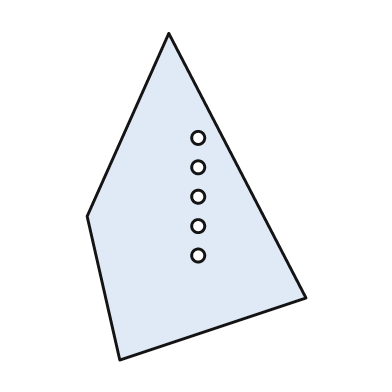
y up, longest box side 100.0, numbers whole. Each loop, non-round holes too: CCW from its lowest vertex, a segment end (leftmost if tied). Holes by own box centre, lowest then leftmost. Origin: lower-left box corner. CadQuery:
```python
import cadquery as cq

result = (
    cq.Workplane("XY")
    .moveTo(10.0, 0.0)
    .lineTo(67.0, 19.0)
    .lineTo(25.0, 100.0)
    .lineTo(0.0, 44.0)
    .close()
    .moveTo(34.0, 32.0)
    .circle(2.0)
    .moveTo(34.0, 41.0)
    .circle(2.0)
    .moveTo(34.0, 50.0)
    .circle(2.0)
    .moveTo(34.0, 59.0)
    .circle(2.0)
    .moveTo(34.0, 68.0)
    .circle(2.0)
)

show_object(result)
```